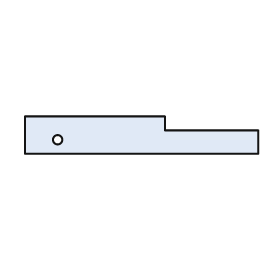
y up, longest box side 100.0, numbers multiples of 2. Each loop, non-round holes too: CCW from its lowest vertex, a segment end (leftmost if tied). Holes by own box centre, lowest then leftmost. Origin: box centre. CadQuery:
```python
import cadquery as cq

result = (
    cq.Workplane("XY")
    .moveTo(-50.0, -8.0)
    .lineTo(50.0, -8.0)
    .lineTo(50.0, 2.0)
    .lineTo(10.0, 2.0)
    .lineTo(10.0, 8.0)
    .lineTo(-50.0, 8.0)
    .close()
    .moveTo(-36.0, -2.0)
    .circle(2.0)
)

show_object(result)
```